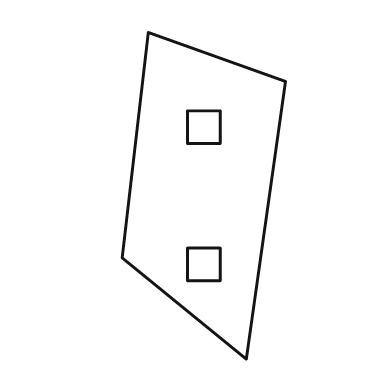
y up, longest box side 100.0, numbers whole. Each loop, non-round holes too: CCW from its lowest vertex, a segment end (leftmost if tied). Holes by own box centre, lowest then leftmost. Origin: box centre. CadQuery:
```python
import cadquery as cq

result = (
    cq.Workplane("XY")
    .moveTo(13.0, -50.0)
    .lineTo(25.0, 35.0)
    .lineTo(-17.0, 50.0)
    .lineTo(-25.0, -19.0)
    .close()
    .moveTo(-5.0, -26.0)
    .lineTo(5.0, -26.0)
    .lineTo(5.0, -16.0)
    .lineTo(-5.0, -16.0)
    .close()
    .moveTo(-5.0, 16.0)
    .lineTo(5.0, 16.0)
    .lineTo(5.0, 26.0)
    .lineTo(-5.0, 26.0)
    .close()
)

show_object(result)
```